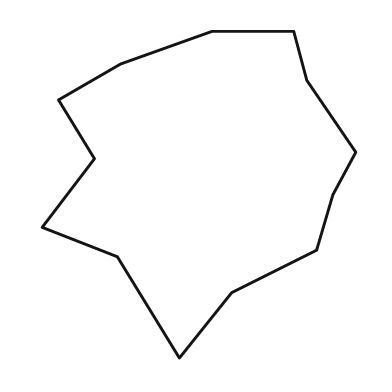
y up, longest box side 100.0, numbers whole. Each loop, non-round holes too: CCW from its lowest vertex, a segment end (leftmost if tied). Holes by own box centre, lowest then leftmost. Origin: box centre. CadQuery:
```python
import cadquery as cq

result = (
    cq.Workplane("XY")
    .moveTo(-6.0, -50.0)
    .lineTo(10.0, -30.0)
    .lineTo(36.0, -17.0)
    .lineTo(41.0, 0.0)
    .lineTo(48.0, 13.0)
    .lineTo(33.0, 35.0)
    .lineTo(29.0, 50.0)
    .lineTo(4.0, 50.0)
    .lineTo(-24.0, 40.0)
    .lineTo(-43.0, 29.0)
    .lineTo(-32.0, 11.0)
    .lineTo(-48.0, -10.0)
    .lineTo(-25.0, -19.0)
    .close()
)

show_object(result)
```